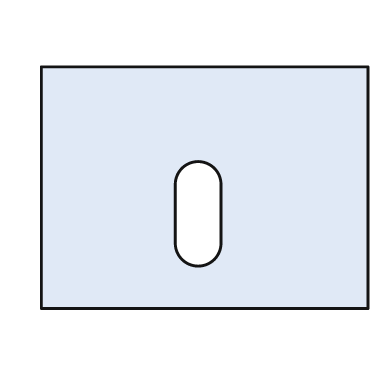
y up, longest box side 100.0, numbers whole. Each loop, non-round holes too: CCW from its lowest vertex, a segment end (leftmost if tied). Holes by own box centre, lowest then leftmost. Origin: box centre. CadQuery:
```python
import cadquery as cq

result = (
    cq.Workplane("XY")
    .moveTo(-50.0, -37.0)
    .lineTo(50.0, -37.0)
    .lineTo(50.0, 37.0)
    .lineTo(-50.0, 37.0)
    .close()
    .moveTo(-9.0, -17.0)
    .threePointArc((-2.0, -24.0), (5.0, -17.0))
    .lineTo(5.0, 1.0)
    .threePointArc((-2.0, 8.0), (-9.0, 1.0))
    .close()
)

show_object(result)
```